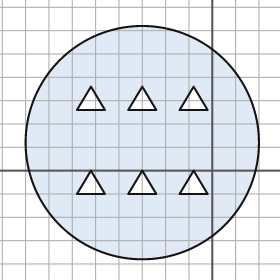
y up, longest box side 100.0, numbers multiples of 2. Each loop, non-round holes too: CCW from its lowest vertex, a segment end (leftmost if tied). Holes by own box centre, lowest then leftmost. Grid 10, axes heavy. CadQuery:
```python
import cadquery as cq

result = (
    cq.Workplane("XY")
    .moveTo(-30.0, 12.0)
    .circle(50.0)
    .moveTo(-58.0, -10.0)
    .lineTo(-46.0, -10.0)
    .lineTo(-52.0, 0.0)
    .close()
    .moveTo(-36.0, -10.0)
    .lineTo(-24.0, -10.0)
    .lineTo(-30.0, 0.0)
    .close()
    .moveTo(-14.0, -10.0)
    .lineTo(-2.0, -10.0)
    .lineTo(-8.0, 0.0)
    .close()
    .moveTo(-58.0, 26.0)
    .lineTo(-46.0, 26.0)
    .lineTo(-52.0, 36.0)
    .close()
    .moveTo(-36.0, 26.0)
    .lineTo(-24.0, 26.0)
    .lineTo(-30.0, 36.0)
    .close()
    .moveTo(-14.0, 26.0)
    .lineTo(-2.0, 26.0)
    .lineTo(-8.0, 36.0)
    .close()
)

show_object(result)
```